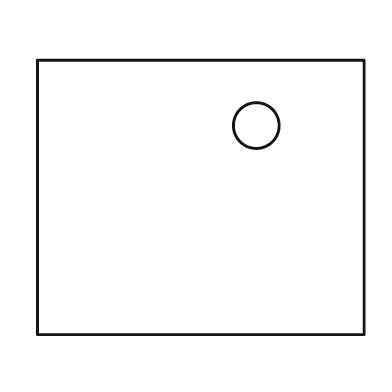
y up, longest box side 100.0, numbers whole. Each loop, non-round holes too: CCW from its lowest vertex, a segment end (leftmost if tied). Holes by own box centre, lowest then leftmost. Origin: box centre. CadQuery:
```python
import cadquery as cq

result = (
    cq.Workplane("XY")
    .moveTo(-50.0, -42.0)
    .lineTo(50.0, -42.0)
    .lineTo(50.0, 42.0)
    .lineTo(-50.0, 42.0)
    .close()
    .moveTo(17.0, 22.0)
    .circle(7.0)
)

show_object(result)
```